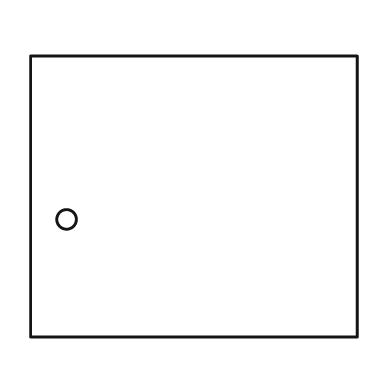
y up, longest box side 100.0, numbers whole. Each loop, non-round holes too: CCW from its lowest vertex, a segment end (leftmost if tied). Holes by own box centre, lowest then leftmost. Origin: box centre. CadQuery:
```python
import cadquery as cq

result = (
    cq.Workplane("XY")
    .moveTo(-50.0, -43.0)
    .lineTo(50.0, -43.0)
    .lineTo(50.0, 43.0)
    .lineTo(-50.0, 43.0)
    .close()
    .moveTo(-39.0, -7.0)
    .circle(3.0)
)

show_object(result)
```